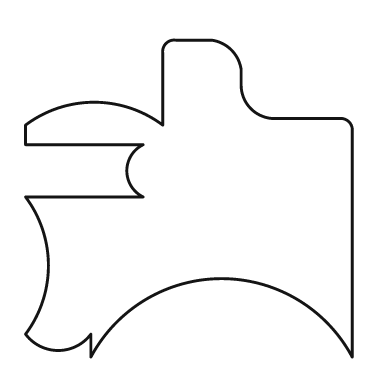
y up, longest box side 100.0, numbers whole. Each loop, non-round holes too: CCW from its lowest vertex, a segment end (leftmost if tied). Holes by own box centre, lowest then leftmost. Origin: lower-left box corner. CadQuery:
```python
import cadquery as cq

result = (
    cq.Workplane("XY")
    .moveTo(20.0, 0.0)
    .threePointArc((60.0, 24.0), (100.0, 0.0))
    .lineTo(100.0, 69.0)
    .threePointArc((99.0, 72.0), (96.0, 73.0))
    .lineTo(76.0, 73.0)
    .threePointArc((69.0, 76.0), (66.0, 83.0))
    .lineTo(66.0, 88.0)
    .threePointArc((63.0, 94.0), (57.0, 97.0))
    .lineTo(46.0, 97.0)
    .threePointArc((43.0, 96.0), (42.0, 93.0))
    .lineTo(42.0, 71.0)
    .threePointArc((21.0, 78.0), (0.0, 71.0))
    .lineTo(0.0, 65.0)
    .lineTo(36.0, 65.0)
    .threePointArc((31.0, 57.0), (36.0, 49.0))
    .lineTo(0.0, 49.0)
    .threePointArc((7.0, 28.0), (0.0, 7.0))
    .threePointArc((10.0, 2.0), (20.0, 7.0))
    .close()
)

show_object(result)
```